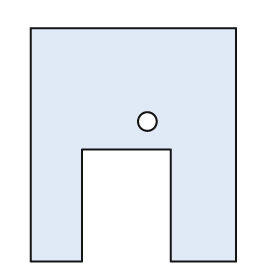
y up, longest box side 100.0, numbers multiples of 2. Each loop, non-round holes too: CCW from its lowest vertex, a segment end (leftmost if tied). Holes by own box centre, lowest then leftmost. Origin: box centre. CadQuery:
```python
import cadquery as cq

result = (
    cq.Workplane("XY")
    .moveTo(-44.0, -50.0)
    .lineTo(-22.0, -50.0)
    .lineTo(-22.0, -2.0)
    .lineTo(16.0, -2.0)
    .lineTo(16.0, -50.0)
    .lineTo(44.0, -50.0)
    .lineTo(44.0, 50.0)
    .lineTo(-44.0, 50.0)
    .close()
    .moveTo(6.0, 10.0)
    .circle(4.0)
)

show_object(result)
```